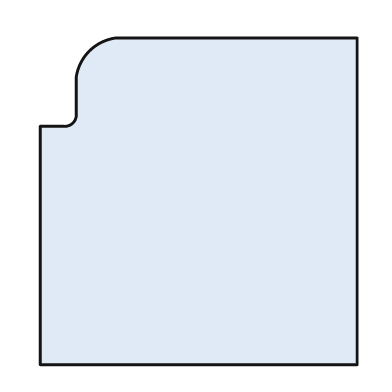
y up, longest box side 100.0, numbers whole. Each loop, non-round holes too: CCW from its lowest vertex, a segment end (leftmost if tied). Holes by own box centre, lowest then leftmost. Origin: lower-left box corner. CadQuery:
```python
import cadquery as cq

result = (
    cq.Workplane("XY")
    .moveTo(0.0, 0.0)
    .lineTo(97.0, 0.0)
    .lineTo(97.0, 100.0)
    .lineTo(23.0, 100.0)
    .threePointArc((15.0, 96.0), (11.0, 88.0))
    .lineTo(11.0, 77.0)
    .threePointArc((10.0, 74.0), (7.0, 73.0))
    .lineTo(0.0, 73.0)
    .close()
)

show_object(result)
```